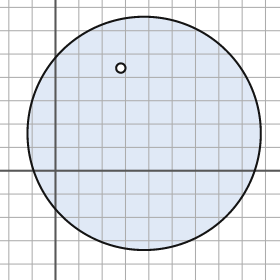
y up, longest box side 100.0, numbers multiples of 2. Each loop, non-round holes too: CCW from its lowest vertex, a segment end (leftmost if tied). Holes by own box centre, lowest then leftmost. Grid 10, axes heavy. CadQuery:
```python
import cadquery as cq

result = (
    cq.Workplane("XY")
    .moveTo(38.0, 16.0)
    .circle(50.0)
    .moveTo(28.0, 44.0)
    .circle(2.0)
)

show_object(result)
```